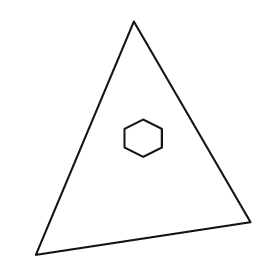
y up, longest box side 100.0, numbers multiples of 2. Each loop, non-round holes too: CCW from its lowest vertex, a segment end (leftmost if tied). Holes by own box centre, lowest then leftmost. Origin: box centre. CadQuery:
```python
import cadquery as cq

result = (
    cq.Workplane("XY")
    .moveTo(-46.0, -50.0)
    .lineTo(46.0, -36.0)
    .lineTo(-4.0, 50.0)
    .close()
    .moveTo(0.0, -8.0)
    .lineTo(8.0, -4.0)
    .lineTo(8.0, 4.0)
    .lineTo(0.0, 8.0)
    .lineTo(-8.0, 4.0)
    .lineTo(-8.0, -4.0)
    .close()
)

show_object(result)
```